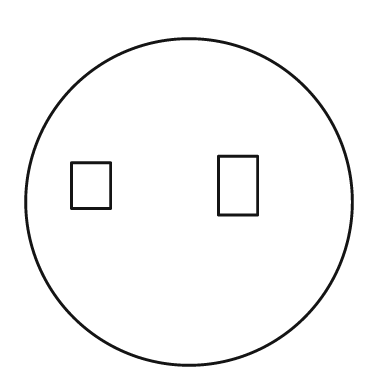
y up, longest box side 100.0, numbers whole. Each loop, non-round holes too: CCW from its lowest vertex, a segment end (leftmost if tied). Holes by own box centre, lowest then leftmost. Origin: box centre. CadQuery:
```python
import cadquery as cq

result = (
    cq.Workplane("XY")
    .moveTo(0.0, 0.0)
    .circle(50.0)
    .moveTo(-36.0, -2.0)
    .lineTo(-24.0, -2.0)
    .lineTo(-24.0, 12.0)
    .lineTo(-36.0, 12.0)
    .close()
    .moveTo(9.0, -4.0)
    .lineTo(21.0, -4.0)
    .lineTo(21.0, 14.0)
    .lineTo(9.0, 14.0)
    .close()
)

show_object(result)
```